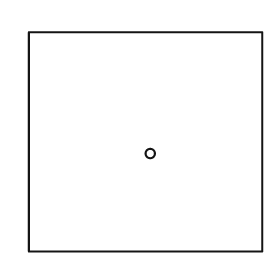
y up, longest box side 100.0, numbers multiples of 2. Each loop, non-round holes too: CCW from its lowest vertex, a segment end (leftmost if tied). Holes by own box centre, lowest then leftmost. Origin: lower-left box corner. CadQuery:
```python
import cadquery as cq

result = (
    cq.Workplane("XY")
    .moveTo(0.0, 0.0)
    .lineTo(100.0, 0.0)
    .lineTo(100.0, 94.0)
    .lineTo(0.0, 94.0)
    .close()
    .moveTo(52.0, 42.0)
    .circle(2.0)
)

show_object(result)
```